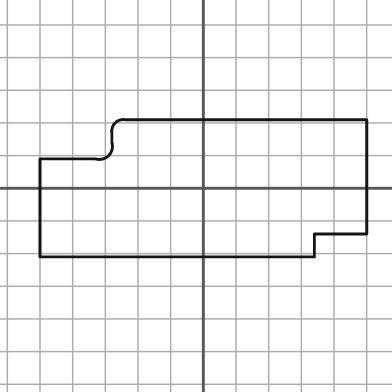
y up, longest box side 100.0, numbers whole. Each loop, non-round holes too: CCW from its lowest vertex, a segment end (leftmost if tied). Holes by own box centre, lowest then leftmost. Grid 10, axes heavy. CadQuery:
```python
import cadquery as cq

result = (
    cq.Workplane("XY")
    .moveTo(-50.0, -21.0)
    .lineTo(34.0, -21.0)
    .lineTo(34.0, -14.0)
    .lineTo(50.0, -14.0)
    .lineTo(50.0, 21.0)
    .lineTo(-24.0, 21.0)
    .threePointArc((-27.0, 20.0), (-28.0, 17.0))
    .lineTo(-28.0, 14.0)
    .threePointArc((-29.0, 10.0), (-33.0, 9.0))
    .lineTo(-50.0, 9.0)
    .close()
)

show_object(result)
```